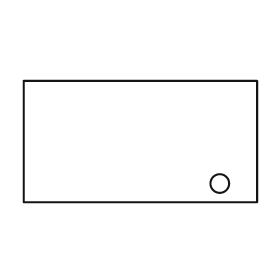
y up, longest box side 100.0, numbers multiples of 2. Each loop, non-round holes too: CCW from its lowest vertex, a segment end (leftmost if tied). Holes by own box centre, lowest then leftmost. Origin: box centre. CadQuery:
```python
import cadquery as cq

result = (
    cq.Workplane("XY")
    .moveTo(-50.0, -26.0)
    .lineTo(50.0, -26.0)
    .lineTo(50.0, 26.0)
    .lineTo(-50.0, 26.0)
    .close()
    .moveTo(34.0, -18.0)
    .circle(4.0)
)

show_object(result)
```